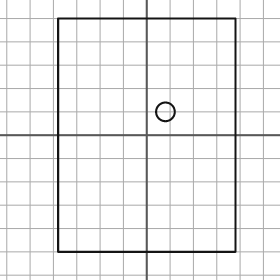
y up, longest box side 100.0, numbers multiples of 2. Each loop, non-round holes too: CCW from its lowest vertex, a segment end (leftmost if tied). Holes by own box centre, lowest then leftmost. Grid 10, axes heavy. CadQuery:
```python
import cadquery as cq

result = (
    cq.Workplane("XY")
    .moveTo(-38.0, -50.0)
    .lineTo(38.0, -50.0)
    .lineTo(38.0, 50.0)
    .lineTo(-38.0, 50.0)
    .close()
    .moveTo(8.0, 10.0)
    .circle(4.0)
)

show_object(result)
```